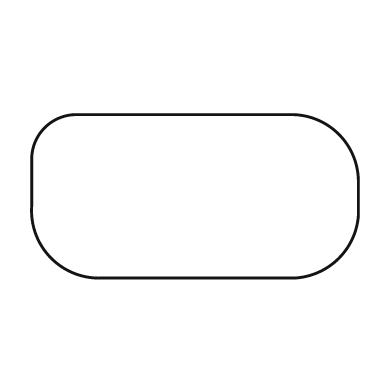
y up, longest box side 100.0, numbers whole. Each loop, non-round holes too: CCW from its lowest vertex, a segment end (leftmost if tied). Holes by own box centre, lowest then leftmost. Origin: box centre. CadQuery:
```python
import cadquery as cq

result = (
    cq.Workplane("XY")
    .moveTo(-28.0, -25.0)
    .lineTo(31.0, -25.0)
    .threePointArc((44.0, -19.0), (50.0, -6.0))
    .lineTo(50.0, 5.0)
    .threePointArc((44.0, 19.0), (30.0, 25.0))
    .lineTo(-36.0, 25.0)
    .threePointArc((-46.0, 21.0), (-50.0, 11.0))
    .lineTo(-50.0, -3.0)
    .threePointArc((-44.0, -19.0), (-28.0, -25.0))
    .close()
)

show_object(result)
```